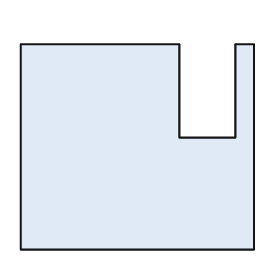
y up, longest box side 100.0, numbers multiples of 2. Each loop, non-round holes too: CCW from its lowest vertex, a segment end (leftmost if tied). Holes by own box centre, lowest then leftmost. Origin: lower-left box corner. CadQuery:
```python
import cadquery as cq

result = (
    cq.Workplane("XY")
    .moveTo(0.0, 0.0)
    .lineTo(100.0, 0.0)
    .lineTo(100.0, 88.0)
    .lineTo(92.0, 88.0)
    .lineTo(92.0, 48.0)
    .lineTo(68.0, 48.0)
    .lineTo(68.0, 88.0)
    .lineTo(0.0, 88.0)
    .close()
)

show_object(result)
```